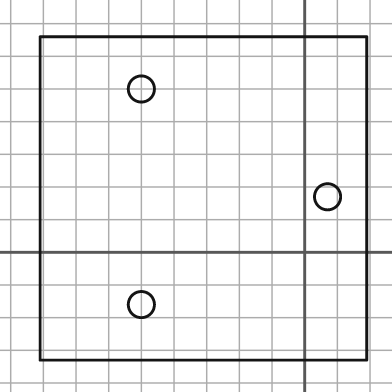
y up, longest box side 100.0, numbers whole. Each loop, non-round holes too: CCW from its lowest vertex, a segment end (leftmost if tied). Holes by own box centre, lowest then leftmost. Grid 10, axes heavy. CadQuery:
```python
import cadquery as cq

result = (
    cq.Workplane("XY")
    .moveTo(-81.0, -33.0)
    .lineTo(19.0, -33.0)
    .lineTo(19.0, 66.0)
    .lineTo(-81.0, 66.0)
    .close()
    .moveTo(-50.0, -16.0)
    .circle(4.0)
    .moveTo(7.0, 17.0)
    .circle(4.0)
    .moveTo(-50.0, 50.0)
    .circle(4.0)
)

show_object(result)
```